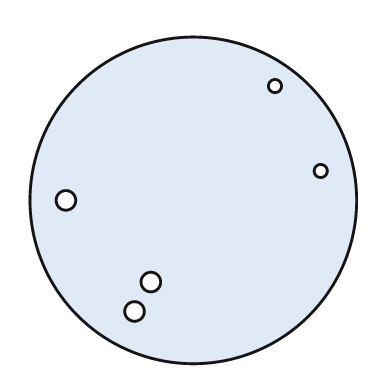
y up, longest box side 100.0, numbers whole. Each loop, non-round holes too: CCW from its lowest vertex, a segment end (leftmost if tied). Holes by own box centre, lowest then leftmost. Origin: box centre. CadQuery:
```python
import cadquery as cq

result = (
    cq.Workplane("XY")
    .moveTo(0.0, 0.0)
    .circle(50.0)
    .moveTo(-18.0, -34.0)
    .circle(3.0)
    .moveTo(-13.0, -25.0)
    .circle(3.0)
    .moveTo(-39.0, 0.0)
    .circle(3.0)
    .moveTo(39.0, 9.0)
    .circle(2.0)
    .moveTo(25.0, 35.0)
    .circle(2.0)
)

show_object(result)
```